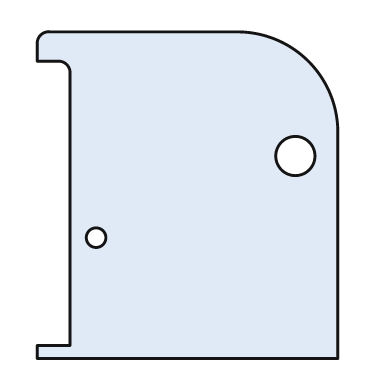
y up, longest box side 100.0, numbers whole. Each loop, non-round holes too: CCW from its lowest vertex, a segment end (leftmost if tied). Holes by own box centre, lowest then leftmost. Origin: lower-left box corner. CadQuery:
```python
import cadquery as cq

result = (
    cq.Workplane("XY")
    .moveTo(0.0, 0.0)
    .lineTo(92.0, 0.0)
    .lineTo(92.0, 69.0)
    .threePointArc((83.0, 91.0), (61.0, 100.0))
    .lineTo(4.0, 100.0)
    .threePointArc((1.0, 99.0), (0.0, 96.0))
    .lineTo(0.0, 91.0)
    .lineTo(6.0, 91.0)
    .threePointArc((9.0, 90.0), (10.0, 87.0))
    .lineTo(10.0, 4.0)
    .lineTo(0.0, 4.0)
    .close()
    .moveTo(18.0, 37.0)
    .circle(3.0)
    .moveTo(79.0, 62.0)
    .circle(6.0)
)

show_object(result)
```